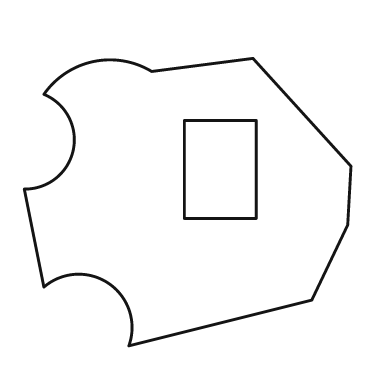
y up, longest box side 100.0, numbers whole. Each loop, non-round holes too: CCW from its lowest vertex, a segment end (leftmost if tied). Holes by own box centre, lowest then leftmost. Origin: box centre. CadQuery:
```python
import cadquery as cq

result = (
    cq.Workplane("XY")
    .moveTo(-18.0, -44.0)
    .lineTo(38.0, -30.0)
    .lineTo(49.0, -7.0)
    .lineTo(50.0, 11.0)
    .lineTo(20.0, 44.0)
    .lineTo(-11.0, 40.0)
    .threePointArc((-29.0, 43.0), (-44.0, 33.0))
    .threePointArc((-35.0, 16.0), (-50.0, 4.0))
    .lineTo(-44.0, -26.0)
    .threePointArc((-24.0, -25.0), (-18.0, -44.0))
    .close()
    .moveTo(-1.0, -5.0)
    .lineTo(21.0, -5.0)
    .lineTo(21.0, 25.0)
    .lineTo(-1.0, 25.0)
    .close()
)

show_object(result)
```